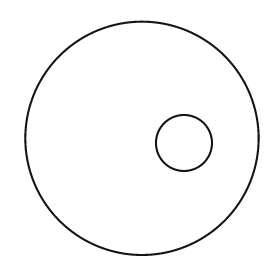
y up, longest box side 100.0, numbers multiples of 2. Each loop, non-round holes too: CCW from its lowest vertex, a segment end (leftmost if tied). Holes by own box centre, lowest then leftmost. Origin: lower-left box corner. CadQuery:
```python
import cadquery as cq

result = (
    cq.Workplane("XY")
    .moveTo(50.0, 50.0)
    .circle(50.0)
    .moveTo(68.0, 48.0)
    .circle(12.0)
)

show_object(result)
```